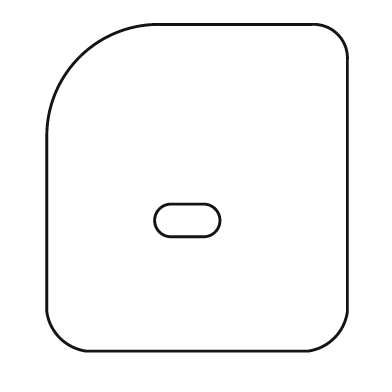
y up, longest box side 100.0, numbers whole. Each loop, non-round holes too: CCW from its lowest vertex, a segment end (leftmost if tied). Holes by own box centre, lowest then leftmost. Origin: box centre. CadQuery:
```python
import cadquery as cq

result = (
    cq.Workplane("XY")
    .moveTo(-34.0, -50.0)
    .lineTo(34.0, -50.0)
    .threePointArc((42.0, -46.0), (46.0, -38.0))
    .lineTo(46.0, 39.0)
    .threePointArc((43.0, 47.0), (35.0, 50.0))
    .lineTo(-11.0, 50.0)
    .threePointArc((-36.0, 40.0), (-46.0, 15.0))
    .lineTo(-46.0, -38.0)
    .threePointArc((-42.0, -46.0), (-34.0, -50.0))
    .close()
    .moveTo(-8.0, -15.0)
    .lineTo(2.0, -15.0)
    .threePointArc((7.0, -10.0), (2.0, -5.0))
    .lineTo(-8.0, -5.0)
    .threePointArc((-13.0, -10.0), (-8.0, -15.0))
    .close()
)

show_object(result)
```